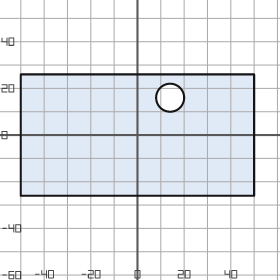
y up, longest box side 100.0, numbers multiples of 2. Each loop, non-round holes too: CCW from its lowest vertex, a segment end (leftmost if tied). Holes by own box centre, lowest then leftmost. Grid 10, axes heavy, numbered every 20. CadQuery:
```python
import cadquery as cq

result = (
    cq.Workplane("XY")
    .moveTo(-50.0, -26.0)
    .lineTo(50.0, -26.0)
    .lineTo(50.0, 26.0)
    .lineTo(-50.0, 26.0)
    .close()
    .moveTo(14.0, 16.0)
    .circle(6.0)
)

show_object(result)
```